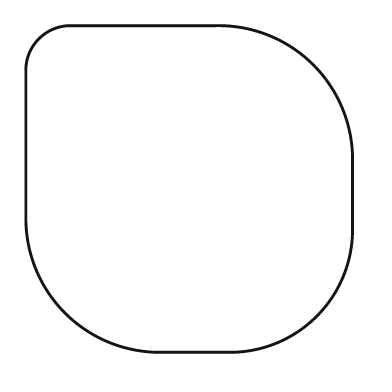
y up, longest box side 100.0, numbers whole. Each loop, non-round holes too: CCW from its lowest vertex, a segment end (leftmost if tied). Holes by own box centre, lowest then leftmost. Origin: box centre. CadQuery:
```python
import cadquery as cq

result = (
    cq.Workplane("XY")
    .moveTo(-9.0, -50.0)
    .lineTo(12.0, -50.0)
    .threePointArc((39.0, -39.0), (50.0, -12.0))
    .lineTo(50.0, 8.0)
    .threePointArc((38.0, 38.0), (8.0, 50.0))
    .lineTo(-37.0, 50.0)
    .threePointArc((-46.0, 46.0), (-50.0, 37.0))
    .lineTo(-50.0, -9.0)
    .threePointArc((-38.0, -38.0), (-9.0, -50.0))
    .close()
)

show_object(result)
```